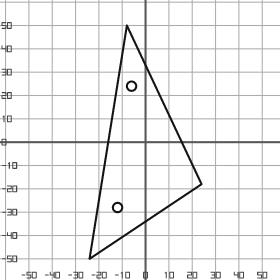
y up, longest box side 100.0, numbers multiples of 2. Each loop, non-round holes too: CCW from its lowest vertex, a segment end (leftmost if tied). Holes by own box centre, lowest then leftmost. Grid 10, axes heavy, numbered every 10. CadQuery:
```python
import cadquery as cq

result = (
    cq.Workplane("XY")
    .moveTo(-24.0, -50.0)
    .lineTo(24.0, -18.0)
    .lineTo(-8.0, 50.0)
    .close()
    .moveTo(-12.0, -28.0)
    .circle(2.0)
    .moveTo(-6.0, 24.0)
    .circle(2.0)
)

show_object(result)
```